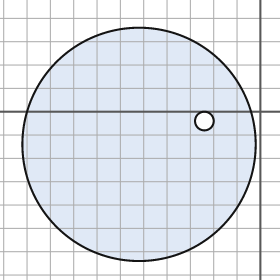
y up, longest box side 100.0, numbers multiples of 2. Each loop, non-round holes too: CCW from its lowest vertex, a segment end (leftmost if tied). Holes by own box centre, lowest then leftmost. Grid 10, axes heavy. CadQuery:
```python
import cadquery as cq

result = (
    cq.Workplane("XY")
    .moveTo(-52.0, -14.0)
    .circle(50.0)
    .moveTo(-24.0, -4.0)
    .circle(4.0)
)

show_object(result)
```